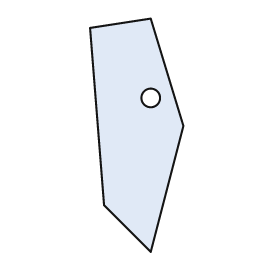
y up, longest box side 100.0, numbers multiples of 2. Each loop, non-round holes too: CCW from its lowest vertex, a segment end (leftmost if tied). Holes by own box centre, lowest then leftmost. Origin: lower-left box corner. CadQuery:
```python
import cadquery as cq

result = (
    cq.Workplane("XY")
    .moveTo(26.0, 0.0)
    .lineTo(40.0, 54.0)
    .lineTo(26.0, 100.0)
    .lineTo(0.0, 96.0)
    .lineTo(6.0, 20.0)
    .close()
    .moveTo(26.0, 66.0)
    .circle(4.0)
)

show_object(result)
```